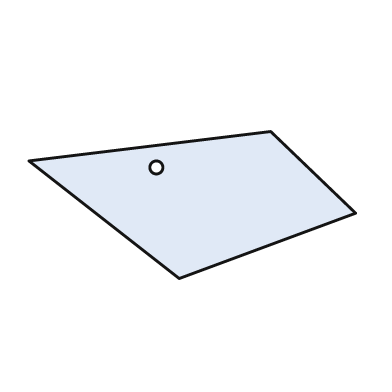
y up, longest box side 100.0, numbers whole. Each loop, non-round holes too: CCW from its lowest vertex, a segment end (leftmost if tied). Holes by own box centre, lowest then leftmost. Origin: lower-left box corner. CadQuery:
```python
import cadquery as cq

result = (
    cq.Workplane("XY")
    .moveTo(46.0, 0.0)
    .lineTo(100.0, 20.0)
    .lineTo(74.0, 45.0)
    .lineTo(0.0, 36.0)
    .close()
    .moveTo(39.0, 34.0)
    .circle(2.0)
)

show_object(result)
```